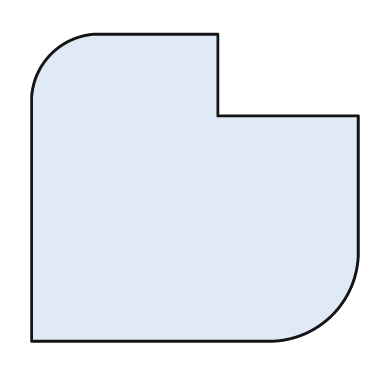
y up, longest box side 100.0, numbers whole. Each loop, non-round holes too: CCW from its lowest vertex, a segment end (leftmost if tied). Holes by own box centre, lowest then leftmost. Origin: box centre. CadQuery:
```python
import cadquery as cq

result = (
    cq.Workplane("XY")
    .moveTo(-50.0, -47.0)
    .lineTo(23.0, -47.0)
    .threePointArc((42.0, -39.0), (50.0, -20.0))
    .lineTo(50.0, 22.0)
    .lineTo(7.0, 22.0)
    .lineTo(7.0, 47.0)
    .lineTo(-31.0, 47.0)
    .threePointArc((-44.0, 41.0), (-50.0, 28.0))
    .close()
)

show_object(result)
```